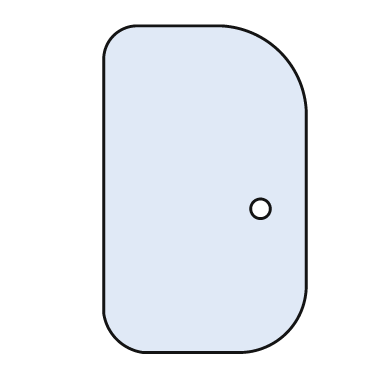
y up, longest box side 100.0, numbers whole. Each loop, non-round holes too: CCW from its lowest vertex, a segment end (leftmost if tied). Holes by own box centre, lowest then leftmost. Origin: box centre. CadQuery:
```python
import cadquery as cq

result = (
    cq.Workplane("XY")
    .moveTo(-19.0, -50.0)
    .lineTo(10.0, -50.0)
    .threePointArc((25.0, -44.0), (31.0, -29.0))
    .lineTo(31.0, 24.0)
    .threePointArc((23.0, 42.0), (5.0, 50.0))
    .lineTo(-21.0, 50.0)
    .threePointArc((-28.0, 47.0), (-31.0, 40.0))
    .lineTo(-31.0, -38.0)
    .threePointArc((-27.0, -46.0), (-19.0, -50.0))
    .close()
    .moveTo(17.0, -6.0)
    .circle(3.0)
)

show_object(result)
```